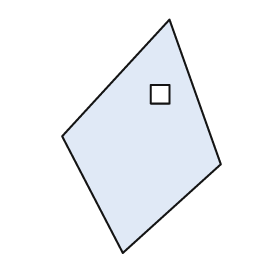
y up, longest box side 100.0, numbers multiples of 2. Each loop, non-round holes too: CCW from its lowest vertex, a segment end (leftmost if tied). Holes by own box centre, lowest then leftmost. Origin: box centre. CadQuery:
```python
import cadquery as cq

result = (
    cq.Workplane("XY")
    .moveTo(-8.0, -50.0)
    .lineTo(34.0, -12.0)
    .lineTo(12.0, 50.0)
    .lineTo(-34.0, 0.0)
    .close()
    .moveTo(4.0, 14.0)
    .lineTo(12.0, 14.0)
    .lineTo(12.0, 22.0)
    .lineTo(4.0, 22.0)
    .close()
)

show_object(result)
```